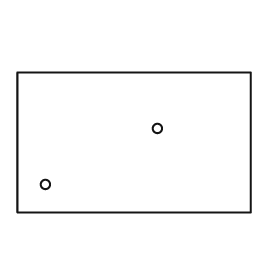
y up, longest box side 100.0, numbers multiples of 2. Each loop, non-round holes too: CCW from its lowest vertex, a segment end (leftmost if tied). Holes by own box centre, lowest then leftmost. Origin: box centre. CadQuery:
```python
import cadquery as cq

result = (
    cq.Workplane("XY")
    .moveTo(-50.0, -30.0)
    .lineTo(50.0, -30.0)
    .lineTo(50.0, 30.0)
    .lineTo(-50.0, 30.0)
    .close()
    .moveTo(-38.0, -18.0)
    .circle(2.0)
    .moveTo(10.0, 6.0)
    .circle(2.0)
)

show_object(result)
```